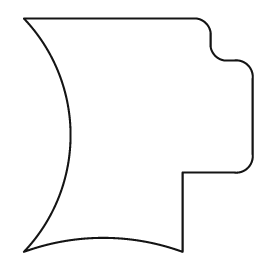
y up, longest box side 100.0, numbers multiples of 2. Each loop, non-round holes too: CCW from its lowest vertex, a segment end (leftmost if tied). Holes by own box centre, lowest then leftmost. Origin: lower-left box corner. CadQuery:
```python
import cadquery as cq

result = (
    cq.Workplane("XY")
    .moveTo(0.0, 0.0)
    .threePointArc((34.0, 6.0), (68.0, 0.0))
    .lineTo(68.0, 34.0)
    .lineTo(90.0, 34.0)
    .threePointArc((96.0, 36.0), (98.0, 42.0))
    .lineTo(98.0, 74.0)
    .threePointArc((96.0, 80.0), (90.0, 82.0))
    .lineTo(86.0, 82.0)
    .threePointArc((82.0, 84.0), (80.0, 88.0))
    .lineTo(80.0, 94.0)
    .threePointArc((78.0, 98.0), (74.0, 100.0))
    .lineTo(0.0, 100.0)
    .threePointArc((20.0, 50.0), (0.0, 0.0))
    .close()
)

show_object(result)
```